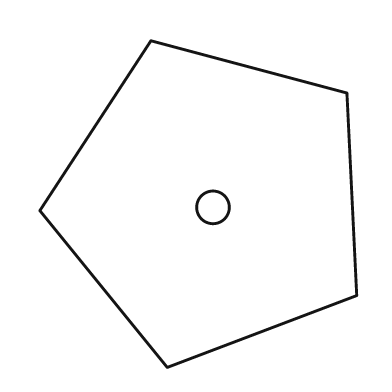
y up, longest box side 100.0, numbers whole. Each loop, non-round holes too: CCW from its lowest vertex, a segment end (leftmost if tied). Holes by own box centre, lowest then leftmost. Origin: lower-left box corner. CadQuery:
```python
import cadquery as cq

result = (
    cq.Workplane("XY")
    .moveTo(39.0, 0.0)
    .lineTo(97.0, 22.0)
    .lineTo(94.0, 84.0)
    .lineTo(34.0, 100.0)
    .lineTo(0.0, 48.0)
    .close()
    .moveTo(53.0, 49.0)
    .circle(5.0)
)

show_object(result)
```